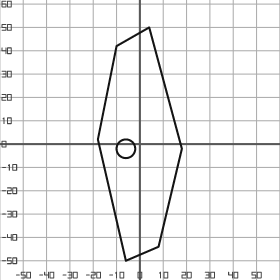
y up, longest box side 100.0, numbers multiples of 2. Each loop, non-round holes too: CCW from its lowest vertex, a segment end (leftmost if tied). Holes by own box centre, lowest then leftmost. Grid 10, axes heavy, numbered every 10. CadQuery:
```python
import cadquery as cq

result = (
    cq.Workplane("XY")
    .moveTo(-6.0, -50.0)
    .lineTo(8.0, -44.0)
    .lineTo(18.0, -2.0)
    .lineTo(4.0, 50.0)
    .lineTo(-10.0, 42.0)
    .lineTo(-18.0, 2.0)
    .close()
    .moveTo(-6.0, -2.0)
    .circle(4.0)
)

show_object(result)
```